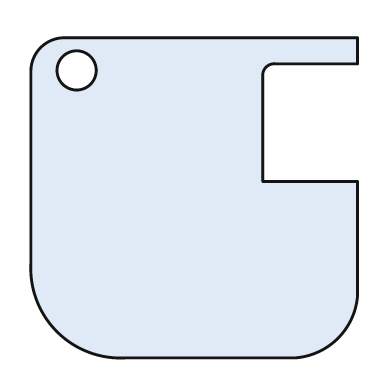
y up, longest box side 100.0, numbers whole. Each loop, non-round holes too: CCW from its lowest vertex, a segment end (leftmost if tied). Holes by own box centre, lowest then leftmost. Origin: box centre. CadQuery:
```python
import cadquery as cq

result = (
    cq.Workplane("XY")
    .moveTo(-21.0, -49.0)
    .lineTo(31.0, -49.0)
    .threePointArc((44.0, -43.0), (50.0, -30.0))
    .lineTo(50.0, 5.0)
    .lineTo(21.0, 5.0)
    .lineTo(21.0, 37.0)
    .threePointArc((22.0, 40.0), (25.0, 41.0))
    .lineTo(50.0, 41.0)
    .lineTo(50.0, 49.0)
    .lineTo(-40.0, 49.0)
    .threePointArc((-47.0, 46.0), (-50.0, 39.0))
    .lineTo(-50.0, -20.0)
    .threePointArc((-42.0, -41.0), (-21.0, -49.0))
    .close()
    .moveTo(-36.0, 39.0)
    .circle(6.0)
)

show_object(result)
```